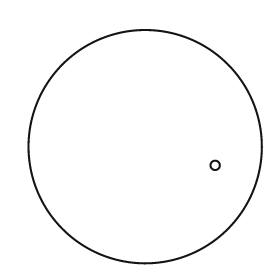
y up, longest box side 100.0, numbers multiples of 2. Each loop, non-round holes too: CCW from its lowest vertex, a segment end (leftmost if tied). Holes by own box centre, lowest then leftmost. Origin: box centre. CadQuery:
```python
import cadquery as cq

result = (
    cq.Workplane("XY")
    .moveTo(0.0, 0.0)
    .circle(50.0)
    .moveTo(30.0, -8.0)
    .circle(2.0)
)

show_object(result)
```